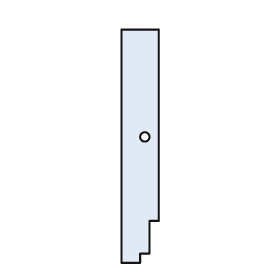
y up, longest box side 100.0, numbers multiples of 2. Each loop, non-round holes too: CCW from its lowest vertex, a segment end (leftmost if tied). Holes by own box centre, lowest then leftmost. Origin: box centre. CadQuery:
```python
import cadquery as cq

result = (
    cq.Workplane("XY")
    .moveTo(-8.0, -50.0)
    .lineTo(0.0, -50.0)
    .lineTo(0.0, -46.0)
    .lineTo(4.0, -46.0)
    .lineTo(4.0, -32.0)
    .lineTo(8.0, -32.0)
    .lineTo(8.0, 50.0)
    .lineTo(-8.0, 50.0)
    .close()
    .moveTo(2.0, 4.0)
    .circle(2.0)
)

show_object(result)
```